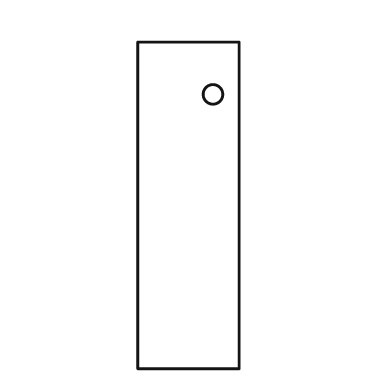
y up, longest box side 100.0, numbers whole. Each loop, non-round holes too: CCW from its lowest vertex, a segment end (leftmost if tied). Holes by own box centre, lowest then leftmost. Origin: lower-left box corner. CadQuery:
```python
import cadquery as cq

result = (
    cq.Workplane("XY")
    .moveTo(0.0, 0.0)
    .lineTo(31.0, 0.0)
    .lineTo(31.0, 100.0)
    .lineTo(0.0, 100.0)
    .close()
    .moveTo(23.0, 84.0)
    .circle(3.0)
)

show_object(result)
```